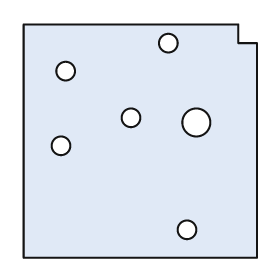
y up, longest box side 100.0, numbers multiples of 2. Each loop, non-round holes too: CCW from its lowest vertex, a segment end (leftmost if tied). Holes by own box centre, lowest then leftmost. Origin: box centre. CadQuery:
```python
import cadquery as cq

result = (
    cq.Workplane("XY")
    .moveTo(-50.0, -50.0)
    .lineTo(50.0, -50.0)
    .lineTo(50.0, 42.0)
    .lineTo(42.0, 42.0)
    .lineTo(42.0, 50.0)
    .lineTo(-50.0, 50.0)
    .close()
    .moveTo(20.0, -38.0)
    .circle(4.0)
    .moveTo(-34.0, -2.0)
    .circle(4.0)
    .moveTo(24.0, 8.0)
    .circle(6.0)
    .moveTo(-4.0, 10.0)
    .circle(4.0)
    .moveTo(-32.0, 30.0)
    .circle(4.0)
    .moveTo(12.0, 42.0)
    .circle(4.0)
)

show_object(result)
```